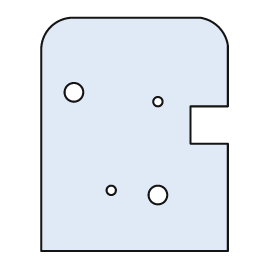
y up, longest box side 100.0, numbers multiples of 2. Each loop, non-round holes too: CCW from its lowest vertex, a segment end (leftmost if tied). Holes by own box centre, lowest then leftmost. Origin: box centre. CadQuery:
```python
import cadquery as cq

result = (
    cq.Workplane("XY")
    .moveTo(-40.0, -50.0)
    .lineTo(40.0, -50.0)
    .lineTo(40.0, -4.0)
    .lineTo(24.0, -4.0)
    .lineTo(24.0, 12.0)
    .lineTo(40.0, 12.0)
    .lineTo(40.0, 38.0)
    .threePointArc((36.0, 46.0), (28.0, 50.0))
    .lineTo(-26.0, 50.0)
    .threePointArc((-36.0, 46.0), (-40.0, 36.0))
    .close()
    .moveTo(10.0, -26.0)
    .circle(4.0)
    .moveTo(-10.0, -24.0)
    .circle(2.0)
    .moveTo(10.0, 14.0)
    .circle(2.0)
    .moveTo(-26.0, 18.0)
    .circle(4.0)
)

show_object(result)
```